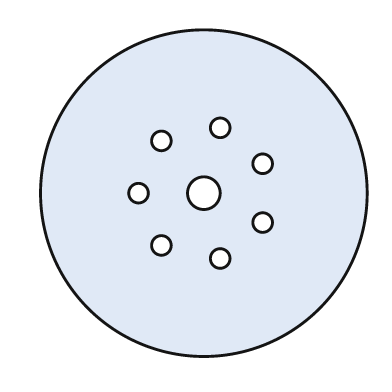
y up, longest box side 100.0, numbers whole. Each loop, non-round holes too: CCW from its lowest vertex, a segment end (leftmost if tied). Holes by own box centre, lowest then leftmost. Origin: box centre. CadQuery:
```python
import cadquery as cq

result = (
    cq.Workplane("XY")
    .moveTo(0.0, 0.0)
    .circle(50.0)
    .moveTo(5.0, -20.0)
    .circle(3.0)
    .moveTo(-13.0, -16.0)
    .circle(3.0)
    .moveTo(18.0, -9.0)
    .circle(3.0)
    .moveTo(-20.0, 0.0)
    .circle(3.0)
    .moveTo(0.0, 0.0)
    .circle(5.0)
    .moveTo(18.0, 9.0)
    .circle(3.0)
    .moveTo(-13.0, 16.0)
    .circle(3.0)
    .moveTo(5.0, 20.0)
    .circle(3.0)
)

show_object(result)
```